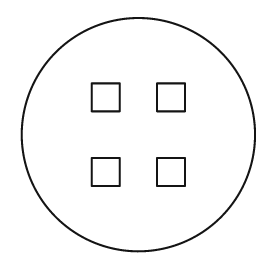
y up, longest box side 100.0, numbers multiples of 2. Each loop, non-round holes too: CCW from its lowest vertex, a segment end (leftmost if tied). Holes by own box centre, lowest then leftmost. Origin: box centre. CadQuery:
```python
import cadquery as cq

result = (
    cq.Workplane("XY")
    .moveTo(0.0, 0.0)
    .circle(50.0)
    .moveTo(-20.0, -22.0)
    .lineTo(-8.0, -22.0)
    .lineTo(-8.0, -10.0)
    .lineTo(-20.0, -10.0)
    .close()
    .moveTo(8.0, -22.0)
    .lineTo(20.0, -22.0)
    .lineTo(20.0, -10.0)
    .lineTo(8.0, -10.0)
    .close()
    .moveTo(-20.0, 10.0)
    .lineTo(-8.0, 10.0)
    .lineTo(-8.0, 22.0)
    .lineTo(-20.0, 22.0)
    .close()
    .moveTo(8.0, 10.0)
    .lineTo(20.0, 10.0)
    .lineTo(20.0, 22.0)
    .lineTo(8.0, 22.0)
    .close()
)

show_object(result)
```